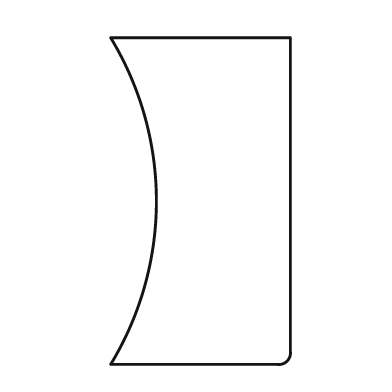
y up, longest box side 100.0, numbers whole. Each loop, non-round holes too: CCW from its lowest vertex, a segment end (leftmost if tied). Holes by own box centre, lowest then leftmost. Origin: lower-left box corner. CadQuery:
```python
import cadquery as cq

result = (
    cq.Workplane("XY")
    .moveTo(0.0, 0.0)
    .lineTo(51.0, 0.0)
    .threePointArc((54.0, 1.0), (55.0, 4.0))
    .lineTo(55.0, 100.0)
    .lineTo(0.0, 100.0)
    .threePointArc((14.0, 50.0), (0.0, 0.0))
    .close()
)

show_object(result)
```